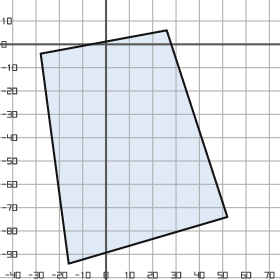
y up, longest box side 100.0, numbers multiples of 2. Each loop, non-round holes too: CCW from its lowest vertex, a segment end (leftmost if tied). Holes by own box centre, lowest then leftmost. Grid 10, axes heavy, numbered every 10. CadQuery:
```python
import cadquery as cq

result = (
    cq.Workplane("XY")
    .moveTo(-16.0, -94.0)
    .lineTo(52.0, -74.0)
    .lineTo(26.0, 6.0)
    .lineTo(-28.0, -4.0)
    .close()
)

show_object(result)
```